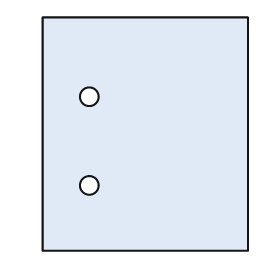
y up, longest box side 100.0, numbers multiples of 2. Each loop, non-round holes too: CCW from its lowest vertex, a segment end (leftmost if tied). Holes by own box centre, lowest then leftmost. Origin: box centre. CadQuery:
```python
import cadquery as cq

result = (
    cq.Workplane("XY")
    .moveTo(-44.0, -50.0)
    .lineTo(44.0, -50.0)
    .lineTo(44.0, 50.0)
    .lineTo(-44.0, 50.0)
    .close()
    .moveTo(-24.0, -22.0)
    .circle(4.0)
    .moveTo(-24.0, 16.0)
    .circle(4.0)
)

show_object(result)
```